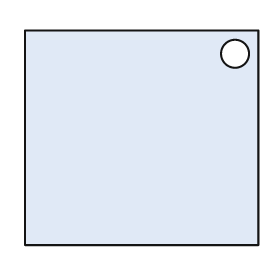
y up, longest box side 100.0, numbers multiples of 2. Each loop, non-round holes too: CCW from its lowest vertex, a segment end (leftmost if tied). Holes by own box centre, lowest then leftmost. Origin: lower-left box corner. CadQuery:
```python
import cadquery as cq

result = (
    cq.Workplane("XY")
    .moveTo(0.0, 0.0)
    .lineTo(100.0, 0.0)
    .lineTo(100.0, 92.0)
    .lineTo(0.0, 92.0)
    .close()
    .moveTo(90.0, 82.0)
    .circle(6.0)
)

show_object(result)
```